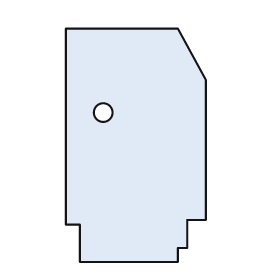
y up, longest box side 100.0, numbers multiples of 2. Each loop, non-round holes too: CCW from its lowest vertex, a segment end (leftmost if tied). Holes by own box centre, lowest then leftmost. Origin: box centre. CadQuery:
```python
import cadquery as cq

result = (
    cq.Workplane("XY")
    .moveTo(-24.0, -50.0)
    .lineTo(18.0, -50.0)
    .lineTo(18.0, -44.0)
    .lineTo(22.0, -44.0)
    .lineTo(22.0, -32.0)
    .lineTo(30.0, -32.0)
    .lineTo(30.0, 28.0)
    .lineTo(18.0, 50.0)
    .lineTo(-30.0, 50.0)
    .lineTo(-30.0, -34.0)
    .lineTo(-24.0, -34.0)
    .close()
    .moveTo(-14.0, 14.0)
    .circle(4.0)
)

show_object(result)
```